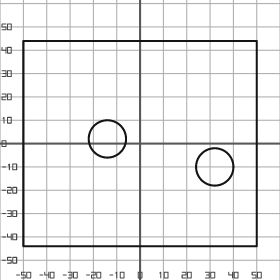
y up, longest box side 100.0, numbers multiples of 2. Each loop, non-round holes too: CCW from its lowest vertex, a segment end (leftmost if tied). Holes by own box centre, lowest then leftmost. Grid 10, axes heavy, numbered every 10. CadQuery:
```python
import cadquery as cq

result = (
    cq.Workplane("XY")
    .moveTo(-50.0, -44.0)
    .lineTo(50.0, -44.0)
    .lineTo(50.0, 44.0)
    .lineTo(-50.0, 44.0)
    .close()
    .moveTo(32.0, -10.0)
    .circle(8.0)
    .moveTo(-14.0, 2.0)
    .circle(8.0)
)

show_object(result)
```